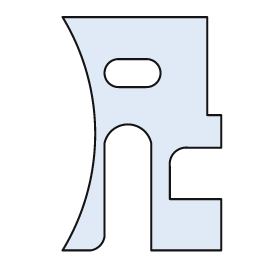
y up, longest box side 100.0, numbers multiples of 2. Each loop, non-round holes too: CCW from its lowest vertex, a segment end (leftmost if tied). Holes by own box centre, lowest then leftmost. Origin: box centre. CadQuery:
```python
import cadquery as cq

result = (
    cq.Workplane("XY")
    .moveTo(-34.0, -50.0)
    .lineTo(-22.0, -50.0)
    .threePointArc((-18.0, -48.0), (-16.0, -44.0))
    .lineTo(-16.0, -4.0)
    .threePointArc((-6.0, 4.0), (4.0, -4.0))
    .lineTo(4.0, -50.0)
    .lineTo(34.0, -50.0)
    .lineTo(34.0, -28.0)
    .lineTo(12.0, -28.0)
    .lineTo(12.0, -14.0)
    .threePointArc((14.0, -8.0), (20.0, -6.0))
    .lineTo(34.0, -6.0)
    .lineTo(34.0, 8.0)
    .lineTo(28.0, 8.0)
    .lineTo(28.0, 50.0)
    .lineTo(-34.0, 50.0)
    .threePointArc((-20.0, 0.0), (-34.0, -50.0))
    .close()
    .moveTo(-10.0, 20.0)
    .lineTo(2.0, 20.0)
    .threePointArc((8.0, 26.0), (2.0, 32.0))
    .lineTo(-10.0, 32.0)
    .threePointArc((-16.0, 26.0), (-10.0, 20.0))
    .close()
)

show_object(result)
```